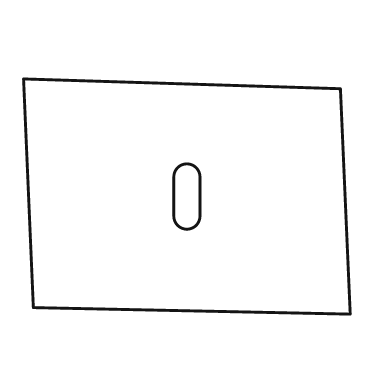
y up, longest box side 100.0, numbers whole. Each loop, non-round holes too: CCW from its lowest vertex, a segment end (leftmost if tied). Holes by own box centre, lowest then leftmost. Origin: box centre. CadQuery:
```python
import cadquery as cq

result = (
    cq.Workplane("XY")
    .moveTo(50.0, -36.0)
    .lineTo(47.0, 33.0)
    .lineTo(-50.0, 36.0)
    .lineTo(-47.0, -34.0)
    .close()
    .moveTo(-4.0, -6.0)
    .threePointArc((0.0, -10.0), (4.0, -6.0))
    .lineTo(4.0, 6.0)
    .threePointArc((0.0, 10.0), (-4.0, 6.0))
    .close()
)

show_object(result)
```